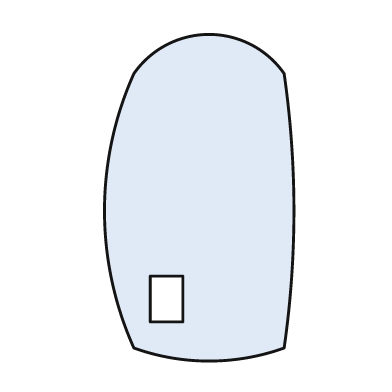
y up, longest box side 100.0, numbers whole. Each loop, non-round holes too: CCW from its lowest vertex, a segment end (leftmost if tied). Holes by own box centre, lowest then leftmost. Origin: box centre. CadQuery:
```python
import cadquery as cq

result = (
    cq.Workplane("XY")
    .moveTo(-20.0, -46.0)
    .threePointArc((3.0, -50.0), (26.0, -46.0))
    .threePointArc((29.0, -4.0), (26.0, 38.0))
    .threePointArc((3.0, 50.0), (-20.0, 38.0))
    .threePointArc((-29.0, -4.0), (-20.0, -46.0))
    .close()
    .moveTo(-15.0, -38.0)
    .lineTo(-5.0, -38.0)
    .lineTo(-5.0, -24.0)
    .lineTo(-15.0, -24.0)
    .close()
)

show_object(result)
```